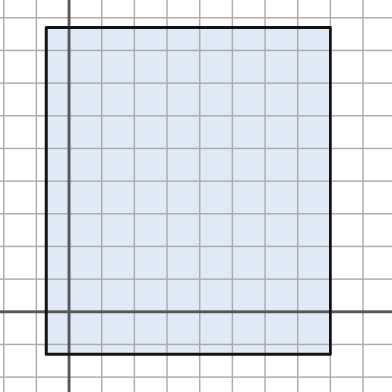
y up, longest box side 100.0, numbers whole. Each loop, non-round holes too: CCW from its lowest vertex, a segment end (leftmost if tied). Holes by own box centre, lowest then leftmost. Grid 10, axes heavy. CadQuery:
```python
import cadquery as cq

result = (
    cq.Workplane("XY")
    .moveTo(-7.0, -13.0)
    .lineTo(80.0, -13.0)
    .lineTo(80.0, 87.0)
    .lineTo(-7.0, 87.0)
    .close()
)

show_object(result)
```